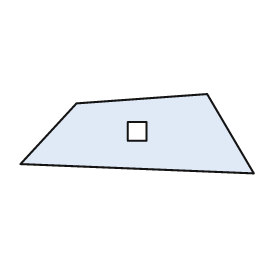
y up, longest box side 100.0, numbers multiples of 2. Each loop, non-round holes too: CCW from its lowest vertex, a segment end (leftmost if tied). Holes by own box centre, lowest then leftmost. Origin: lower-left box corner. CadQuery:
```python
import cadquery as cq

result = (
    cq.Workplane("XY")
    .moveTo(100.0, 0.0)
    .lineTo(80.0, 34.0)
    .lineTo(24.0, 30.0)
    .lineTo(0.0, 4.0)
    .close()
    .moveTo(46.0, 14.0)
    .lineTo(54.0, 14.0)
    .lineTo(54.0, 22.0)
    .lineTo(46.0, 22.0)
    .close()
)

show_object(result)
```